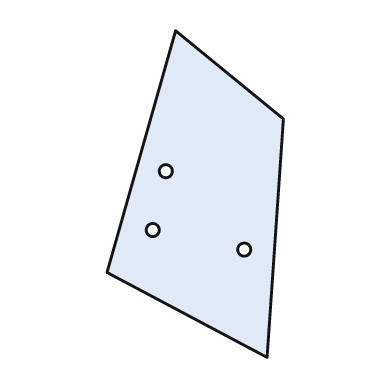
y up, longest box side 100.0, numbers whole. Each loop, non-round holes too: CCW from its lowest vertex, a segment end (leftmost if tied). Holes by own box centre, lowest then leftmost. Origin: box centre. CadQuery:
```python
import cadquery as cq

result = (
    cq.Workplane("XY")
    .moveTo(22.0, -50.0)
    .lineTo(27.0, 23.0)
    .lineTo(-6.0, 50.0)
    .lineTo(-27.0, -24.0)
    .close()
    .moveTo(15.0, -17.0)
    .circle(2.0)
    .moveTo(-13.0, -11.0)
    .circle(2.0)
    .moveTo(-9.0, 7.0)
    .circle(2.0)
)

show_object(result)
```